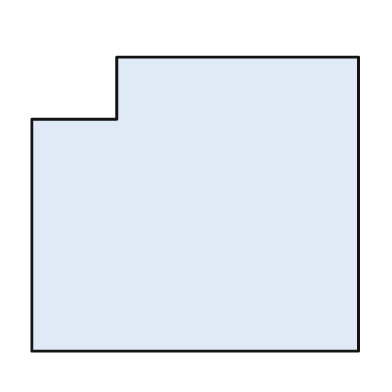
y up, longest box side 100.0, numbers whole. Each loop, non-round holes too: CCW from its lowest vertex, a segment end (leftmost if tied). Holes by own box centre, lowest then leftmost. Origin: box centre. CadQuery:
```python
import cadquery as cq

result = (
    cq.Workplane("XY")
    .moveTo(-50.0, -45.0)
    .lineTo(50.0, -45.0)
    .lineTo(50.0, 45.0)
    .lineTo(-24.0, 45.0)
    .lineTo(-24.0, 26.0)
    .lineTo(-50.0, 26.0)
    .close()
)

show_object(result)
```